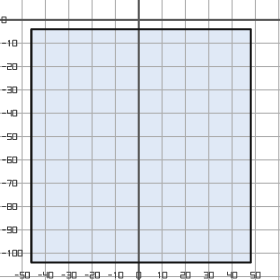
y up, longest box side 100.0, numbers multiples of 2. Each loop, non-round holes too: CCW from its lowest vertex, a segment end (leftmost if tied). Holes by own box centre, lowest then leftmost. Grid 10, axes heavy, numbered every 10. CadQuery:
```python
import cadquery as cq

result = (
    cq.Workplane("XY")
    .moveTo(-46.0, -104.0)
    .lineTo(48.0, -104.0)
    .lineTo(48.0, -4.0)
    .lineTo(-46.0, -4.0)
    .close()
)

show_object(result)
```